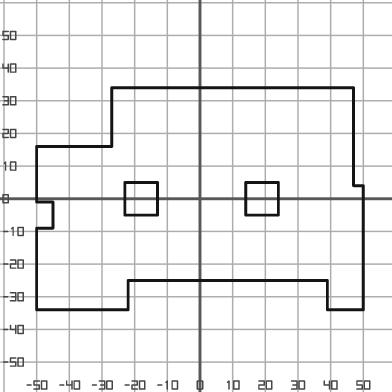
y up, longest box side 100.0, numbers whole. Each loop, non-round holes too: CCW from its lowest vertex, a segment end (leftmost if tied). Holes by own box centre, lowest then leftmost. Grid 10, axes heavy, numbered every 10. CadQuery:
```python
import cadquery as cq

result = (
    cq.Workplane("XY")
    .moveTo(-50.0, -34.0)
    .lineTo(-22.0, -34.0)
    .lineTo(-22.0, -25.0)
    .lineTo(39.0, -25.0)
    .lineTo(39.0, -34.0)
    .lineTo(50.0, -34.0)
    .lineTo(50.0, 4.0)
    .lineTo(47.0, 4.0)
    .lineTo(47.0, 34.0)
    .lineTo(-27.0, 34.0)
    .lineTo(-27.0, 16.0)
    .lineTo(-50.0, 16.0)
    .lineTo(-50.0, -1.0)
    .lineTo(-45.0, -1.0)
    .lineTo(-45.0, -9.0)
    .lineTo(-50.0, -9.0)
    .close()
    .moveTo(-23.0, -5.0)
    .lineTo(-13.0, -5.0)
    .lineTo(-13.0, 5.0)
    .lineTo(-23.0, 5.0)
    .close()
    .moveTo(14.0, -5.0)
    .lineTo(24.0, -5.0)
    .lineTo(24.0, 5.0)
    .lineTo(14.0, 5.0)
    .close()
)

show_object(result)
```